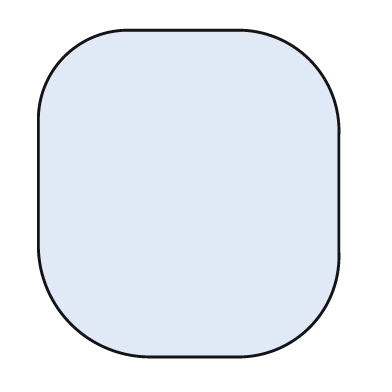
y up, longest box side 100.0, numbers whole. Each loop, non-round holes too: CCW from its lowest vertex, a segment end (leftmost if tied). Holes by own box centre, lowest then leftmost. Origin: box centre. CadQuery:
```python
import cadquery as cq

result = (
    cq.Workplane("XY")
    .moveTo(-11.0, -50.0)
    .lineTo(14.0, -50.0)
    .threePointArc((37.0, -41.0), (46.0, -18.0))
    .lineTo(46.0, 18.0)
    .threePointArc((37.0, 41.0), (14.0, 50.0))
    .lineTo(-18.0, 50.0)
    .threePointArc((-38.0, 42.0), (-46.0, 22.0))
    .lineTo(-46.0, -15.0)
    .threePointArc((-36.0, -40.0), (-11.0, -50.0))
    .close()
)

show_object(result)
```